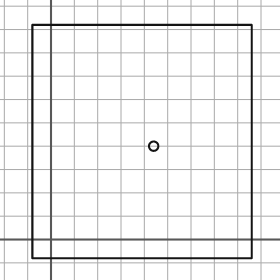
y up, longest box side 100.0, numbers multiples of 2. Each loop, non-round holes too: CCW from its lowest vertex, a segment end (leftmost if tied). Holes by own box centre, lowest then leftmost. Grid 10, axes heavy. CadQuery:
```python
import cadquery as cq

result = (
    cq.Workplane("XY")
    .moveTo(-8.0, -8.0)
    .lineTo(86.0, -8.0)
    .lineTo(86.0, 92.0)
    .lineTo(-8.0, 92.0)
    .close()
    .moveTo(44.0, 40.0)
    .circle(2.0)
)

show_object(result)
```